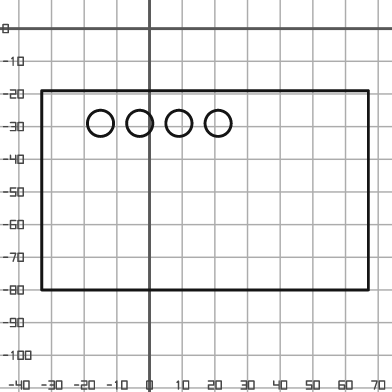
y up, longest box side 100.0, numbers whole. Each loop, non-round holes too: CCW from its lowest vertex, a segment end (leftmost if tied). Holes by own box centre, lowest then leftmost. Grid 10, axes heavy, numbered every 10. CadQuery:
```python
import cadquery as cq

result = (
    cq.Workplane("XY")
    .moveTo(-33.0, -80.0)
    .lineTo(67.0, -80.0)
    .lineTo(67.0, -19.0)
    .lineTo(-33.0, -19.0)
    .close()
    .moveTo(-15.0, -29.0)
    .circle(4.0)
    .moveTo(-3.0, -29.0)
    .circle(4.0)
    .moveTo(9.0, -29.0)
    .circle(4.0)
    .moveTo(21.0, -29.0)
    .circle(4.0)
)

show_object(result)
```